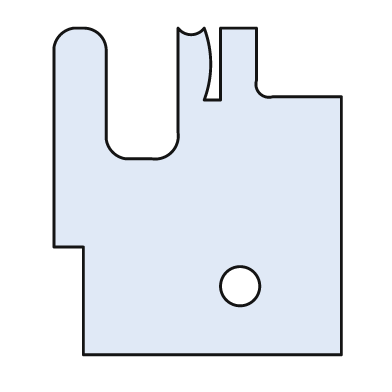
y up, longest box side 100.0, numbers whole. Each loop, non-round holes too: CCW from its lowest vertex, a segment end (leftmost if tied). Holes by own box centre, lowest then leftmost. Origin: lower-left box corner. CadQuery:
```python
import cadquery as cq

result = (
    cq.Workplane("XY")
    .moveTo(9.0, 0.0)
    .lineTo(88.0, 0.0)
    .lineTo(88.0, 79.0)
    .lineTo(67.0, 79.0)
    .threePointArc((63.0, 80.0), (62.0, 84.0))
    .lineTo(62.0, 100.0)
    .lineTo(51.0, 100.0)
    .lineTo(51.0, 78.0)
    .lineTo(46.0, 78.0)
    .threePointArc((48.0, 89.0), (46.0, 100.0))
    .threePointArc((42.0, 98.0), (38.0, 100.0))
    .lineTo(38.0, 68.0)
    .threePointArc((36.0, 62.0), (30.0, 60.0))
    .lineTo(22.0, 60.0)
    .threePointArc((18.0, 62.0), (16.0, 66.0))
    .lineTo(16.0, 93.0)
    .threePointArc((14.0, 98.0), (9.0, 100.0))
    .lineTo(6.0, 100.0)
    .threePointArc((2.0, 98.0), (0.0, 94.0))
    .lineTo(0.0, 33.0)
    .lineTo(9.0, 33.0)
    .close()
    .moveTo(57.0, 21.0)
    .circle(6.0)
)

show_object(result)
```